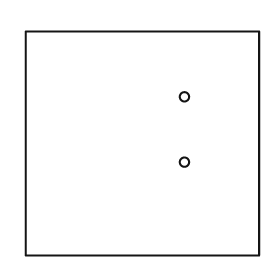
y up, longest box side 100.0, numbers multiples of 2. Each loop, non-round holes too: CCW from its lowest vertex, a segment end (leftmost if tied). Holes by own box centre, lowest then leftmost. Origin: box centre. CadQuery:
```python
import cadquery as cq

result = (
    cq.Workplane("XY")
    .moveTo(-50.0, -48.0)
    .lineTo(50.0, -48.0)
    .lineTo(50.0, 48.0)
    .lineTo(-50.0, 48.0)
    .close()
    .moveTo(18.0, -8.0)
    .circle(2.0)
    .moveTo(18.0, 20.0)
    .circle(2.0)
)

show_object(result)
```